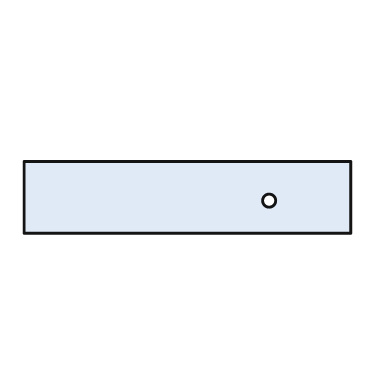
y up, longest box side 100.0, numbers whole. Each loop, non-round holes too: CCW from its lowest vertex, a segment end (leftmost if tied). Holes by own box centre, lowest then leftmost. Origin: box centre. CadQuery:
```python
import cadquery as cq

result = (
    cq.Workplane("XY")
    .moveTo(-50.0, -11.0)
    .lineTo(50.0, -11.0)
    .lineTo(50.0, 11.0)
    .lineTo(-50.0, 11.0)
    .close()
    .moveTo(25.0, -1.0)
    .circle(2.0)
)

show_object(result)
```